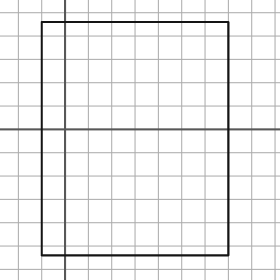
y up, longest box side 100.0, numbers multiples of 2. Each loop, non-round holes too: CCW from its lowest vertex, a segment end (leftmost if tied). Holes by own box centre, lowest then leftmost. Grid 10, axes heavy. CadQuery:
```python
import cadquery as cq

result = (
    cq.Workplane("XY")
    .moveTo(-10.0, -54.0)
    .lineTo(70.0, -54.0)
    .lineTo(70.0, 46.0)
    .lineTo(-10.0, 46.0)
    .close()
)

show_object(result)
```